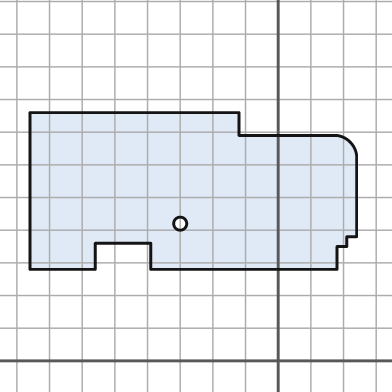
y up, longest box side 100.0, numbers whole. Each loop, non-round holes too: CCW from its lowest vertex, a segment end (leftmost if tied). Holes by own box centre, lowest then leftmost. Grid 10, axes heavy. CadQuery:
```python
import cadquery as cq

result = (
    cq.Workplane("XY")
    .moveTo(-76.0, 28.0)
    .lineTo(-56.0, 28.0)
    .lineTo(-56.0, 36.0)
    .lineTo(-39.0, 36.0)
    .lineTo(-39.0, 28.0)
    .lineTo(18.0, 28.0)
    .lineTo(18.0, 35.0)
    .lineTo(21.0, 35.0)
    .lineTo(21.0, 38.0)
    .lineTo(24.0, 38.0)
    .lineTo(24.0, 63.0)
    .threePointArc((22.0, 67.0), (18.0, 69.0))
    .lineTo(-12.0, 69.0)
    .lineTo(-12.0, 76.0)
    .lineTo(-76.0, 76.0)
    .close()
    .moveTo(-30.0, 42.0)
    .circle(2.0)
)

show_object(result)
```